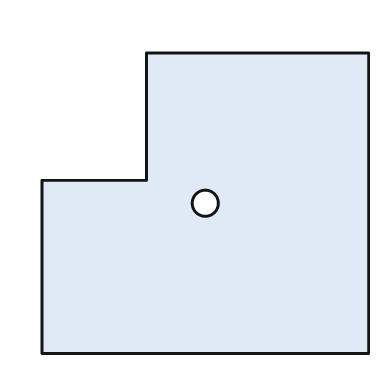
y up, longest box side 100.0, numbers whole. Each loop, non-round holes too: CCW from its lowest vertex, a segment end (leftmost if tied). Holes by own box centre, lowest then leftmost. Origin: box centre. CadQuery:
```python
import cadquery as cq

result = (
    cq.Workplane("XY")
    .moveTo(-50.0, -46.0)
    .lineTo(50.0, -46.0)
    .lineTo(50.0, 46.0)
    .lineTo(-18.0, 46.0)
    .lineTo(-18.0, 7.0)
    .lineTo(-50.0, 7.0)
    .close()
    .moveTo(0.0, 0.0)
    .circle(4.0)
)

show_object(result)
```